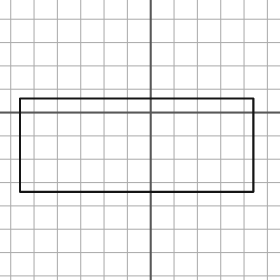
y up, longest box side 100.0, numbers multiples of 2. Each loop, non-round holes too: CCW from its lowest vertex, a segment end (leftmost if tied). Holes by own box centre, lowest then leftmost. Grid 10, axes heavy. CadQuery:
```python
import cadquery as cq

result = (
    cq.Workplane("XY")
    .moveTo(-56.0, -34.0)
    .lineTo(44.0, -34.0)
    .lineTo(44.0, 6.0)
    .lineTo(-56.0, 6.0)
    .close()
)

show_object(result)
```